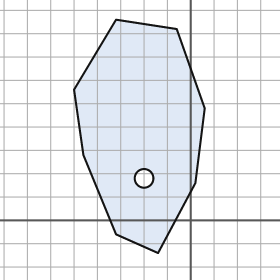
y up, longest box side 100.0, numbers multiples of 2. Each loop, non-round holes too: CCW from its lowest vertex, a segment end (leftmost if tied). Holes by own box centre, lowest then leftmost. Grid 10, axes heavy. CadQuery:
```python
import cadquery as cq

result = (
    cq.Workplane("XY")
    .moveTo(-14.0, -14.0)
    .lineTo(2.0, 16.0)
    .lineTo(6.0, 48.0)
    .lineTo(-6.0, 82.0)
    .lineTo(-32.0, 86.0)
    .lineTo(-50.0, 56.0)
    .lineTo(-46.0, 28.0)
    .lineTo(-32.0, -6.0)
    .close()
    .moveTo(-20.0, 18.0)
    .circle(4.0)
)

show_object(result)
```